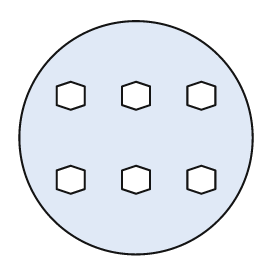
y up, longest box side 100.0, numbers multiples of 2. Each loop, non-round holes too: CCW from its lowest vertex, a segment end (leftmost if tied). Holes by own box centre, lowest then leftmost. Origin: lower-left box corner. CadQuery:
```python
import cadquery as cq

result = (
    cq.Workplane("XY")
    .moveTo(50.0, 50.0)
    .circle(50.0)
    .moveTo(22.0, 26.0)
    .lineTo(28.0, 28.0)
    .lineTo(28.0, 36.0)
    .lineTo(22.0, 38.0)
    .lineTo(16.0, 36.0)
    .lineTo(16.0, 28.0)
    .close()
    .moveTo(50.0, 26.0)
    .lineTo(56.0, 28.0)
    .lineTo(56.0, 36.0)
    .lineTo(50.0, 38.0)
    .lineTo(44.0, 36.0)
    .lineTo(44.0, 28.0)
    .close()
    .moveTo(78.0, 26.0)
    .lineTo(84.0, 28.0)
    .lineTo(84.0, 36.0)
    .lineTo(78.0, 38.0)
    .lineTo(72.0, 36.0)
    .lineTo(72.0, 28.0)
    .close()
    .moveTo(22.0, 62.0)
    .lineTo(28.0, 64.0)
    .lineTo(28.0, 72.0)
    .lineTo(22.0, 74.0)
    .lineTo(16.0, 72.0)
    .lineTo(16.0, 64.0)
    .close()
    .moveTo(50.0, 62.0)
    .lineTo(56.0, 64.0)
    .lineTo(56.0, 72.0)
    .lineTo(50.0, 74.0)
    .lineTo(44.0, 72.0)
    .lineTo(44.0, 64.0)
    .close()
    .moveTo(78.0, 62.0)
    .lineTo(84.0, 64.0)
    .lineTo(84.0, 72.0)
    .lineTo(78.0, 74.0)
    .lineTo(72.0, 72.0)
    .lineTo(72.0, 64.0)
    .close()
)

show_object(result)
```